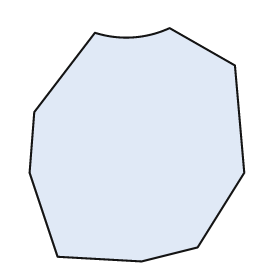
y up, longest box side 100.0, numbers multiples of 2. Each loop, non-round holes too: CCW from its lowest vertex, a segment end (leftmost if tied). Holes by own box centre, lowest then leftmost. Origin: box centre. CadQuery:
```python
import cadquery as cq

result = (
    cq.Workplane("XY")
    .moveTo(2.0, -50.0)
    .lineTo(26.0, -44.0)
    .lineTo(46.0, -12.0)
    .lineTo(42.0, 34.0)
    .lineTo(14.0, 50.0)
    .threePointArc((-2.0, 46.0), (-18.0, 48.0))
    .lineTo(-44.0, 14.0)
    .lineTo(-46.0, -12.0)
    .lineTo(-34.0, -48.0)
    .close()
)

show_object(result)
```